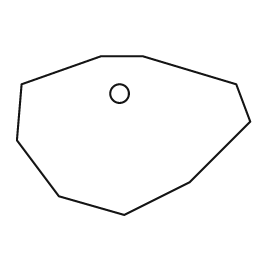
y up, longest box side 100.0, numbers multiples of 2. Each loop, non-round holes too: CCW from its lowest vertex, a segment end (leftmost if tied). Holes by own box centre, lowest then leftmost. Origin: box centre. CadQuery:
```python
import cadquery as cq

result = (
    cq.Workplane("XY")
    .moveTo(-4.0, -34.0)
    .lineTo(24.0, -20.0)
    .lineTo(50.0, 6.0)
    .lineTo(44.0, 22.0)
    .lineTo(4.0, 34.0)
    .lineTo(-14.0, 34.0)
    .lineTo(-48.0, 22.0)
    .lineTo(-50.0, -2.0)
    .lineTo(-32.0, -26.0)
    .close()
    .moveTo(-6.0, 18.0)
    .circle(4.0)
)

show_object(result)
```